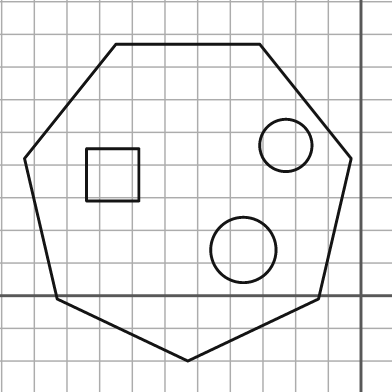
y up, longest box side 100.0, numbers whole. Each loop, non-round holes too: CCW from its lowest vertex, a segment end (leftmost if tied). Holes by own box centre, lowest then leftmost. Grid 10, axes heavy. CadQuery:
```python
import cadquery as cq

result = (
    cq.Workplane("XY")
    .moveTo(-53.0, -20.0)
    .lineTo(-13.0, -1.0)
    .lineTo(-3.0, 42.0)
    .lineTo(-31.0, 77.0)
    .lineTo(-75.0, 77.0)
    .lineTo(-103.0, 42.0)
    .lineTo(-93.0, -1.0)
    .close()
    .moveTo(-36.0, 14.0)
    .circle(10.0)
    .moveTo(-84.0, 29.0)
    .lineTo(-68.0, 29.0)
    .lineTo(-68.0, 45.0)
    .lineTo(-84.0, 45.0)
    .close()
    .moveTo(-23.0, 46.0)
    .circle(8.0)
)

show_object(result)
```